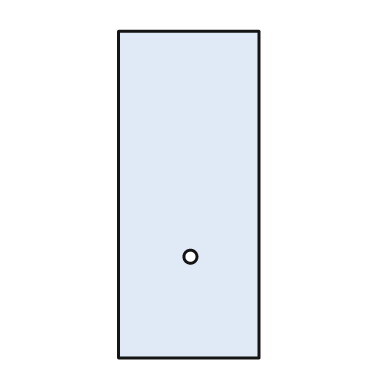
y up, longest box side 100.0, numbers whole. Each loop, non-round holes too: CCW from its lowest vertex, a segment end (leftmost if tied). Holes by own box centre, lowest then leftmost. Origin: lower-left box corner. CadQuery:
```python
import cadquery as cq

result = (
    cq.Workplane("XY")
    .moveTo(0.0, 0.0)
    .lineTo(43.0, 0.0)
    .lineTo(43.0, 100.0)
    .lineTo(0.0, 100.0)
    .close()
    .moveTo(22.0, 31.0)
    .circle(2.0)
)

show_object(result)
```